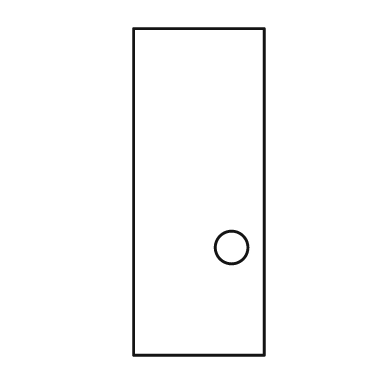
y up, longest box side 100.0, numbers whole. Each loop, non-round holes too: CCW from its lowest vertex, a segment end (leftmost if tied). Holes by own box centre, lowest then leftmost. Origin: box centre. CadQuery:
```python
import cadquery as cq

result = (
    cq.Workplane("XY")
    .moveTo(-20.0, -50.0)
    .lineTo(20.0, -50.0)
    .lineTo(20.0, 50.0)
    .lineTo(-20.0, 50.0)
    .close()
    .moveTo(10.0, -17.0)
    .circle(5.0)
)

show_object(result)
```